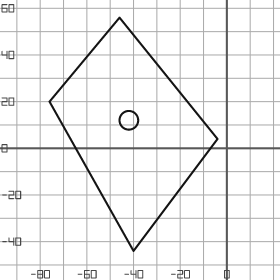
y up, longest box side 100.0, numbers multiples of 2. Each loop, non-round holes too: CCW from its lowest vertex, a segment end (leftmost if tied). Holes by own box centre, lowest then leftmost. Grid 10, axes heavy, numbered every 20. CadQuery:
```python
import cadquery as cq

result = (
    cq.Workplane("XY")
    .moveTo(-40.0, -44.0)
    .lineTo(-4.0, 4.0)
    .lineTo(-46.0, 56.0)
    .lineTo(-76.0, 20.0)
    .close()
    .moveTo(-42.0, 12.0)
    .circle(4.0)
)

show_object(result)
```